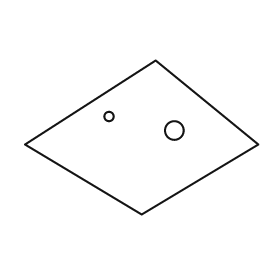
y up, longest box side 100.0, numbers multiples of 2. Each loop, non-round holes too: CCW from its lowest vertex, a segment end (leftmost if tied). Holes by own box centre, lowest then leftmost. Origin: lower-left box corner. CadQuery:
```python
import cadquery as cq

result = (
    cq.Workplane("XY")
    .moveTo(50.0, 0.0)
    .lineTo(100.0, 30.0)
    .lineTo(56.0, 66.0)
    .lineTo(0.0, 30.0)
    .close()
    .moveTo(64.0, 36.0)
    .circle(4.0)
    .moveTo(36.0, 42.0)
    .circle(2.0)
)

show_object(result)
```